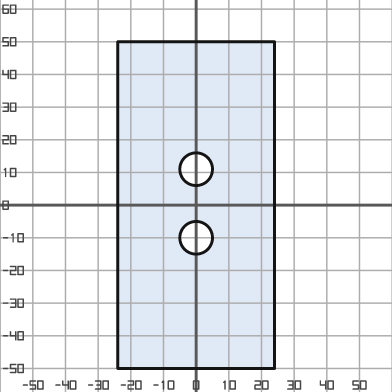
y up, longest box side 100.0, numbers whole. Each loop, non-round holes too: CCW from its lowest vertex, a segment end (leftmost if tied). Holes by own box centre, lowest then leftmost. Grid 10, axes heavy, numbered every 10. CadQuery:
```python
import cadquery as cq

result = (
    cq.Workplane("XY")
    .moveTo(-24.0, -50.0)
    .lineTo(24.0, -50.0)
    .lineTo(24.0, 50.0)
    .lineTo(-24.0, 50.0)
    .close()
    .moveTo(0.0, -10.0)
    .circle(5.0)
    .moveTo(0.0, 11.0)
    .circle(5.0)
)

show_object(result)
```